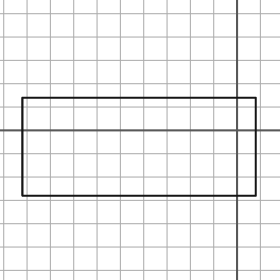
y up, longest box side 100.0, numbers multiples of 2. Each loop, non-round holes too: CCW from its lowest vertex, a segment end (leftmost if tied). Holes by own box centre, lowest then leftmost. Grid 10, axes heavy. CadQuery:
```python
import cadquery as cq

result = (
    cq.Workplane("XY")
    .moveTo(-92.0, -28.0)
    .lineTo(8.0, -28.0)
    .lineTo(8.0, 14.0)
    .lineTo(-92.0, 14.0)
    .close()
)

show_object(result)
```